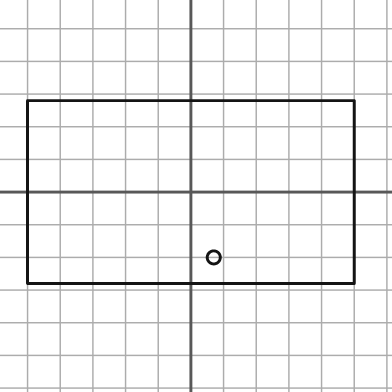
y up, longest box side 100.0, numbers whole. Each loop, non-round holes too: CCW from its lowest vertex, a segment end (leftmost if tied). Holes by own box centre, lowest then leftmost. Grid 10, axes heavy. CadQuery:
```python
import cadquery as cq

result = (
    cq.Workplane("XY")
    .moveTo(-50.0, -28.0)
    .lineTo(50.0, -28.0)
    .lineTo(50.0, 28.0)
    .lineTo(-50.0, 28.0)
    .close()
    .moveTo(7.0, -20.0)
    .circle(2.0)
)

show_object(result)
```